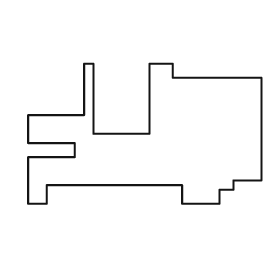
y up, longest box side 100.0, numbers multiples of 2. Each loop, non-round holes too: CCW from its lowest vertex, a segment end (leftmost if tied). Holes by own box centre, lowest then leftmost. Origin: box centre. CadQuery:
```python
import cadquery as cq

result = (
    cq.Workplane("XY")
    .moveTo(-50.0, -30.0)
    .lineTo(-42.0, -30.0)
    .lineTo(-42.0, -22.0)
    .lineTo(16.0, -22.0)
    .lineTo(16.0, -30.0)
    .lineTo(32.0, -30.0)
    .lineTo(32.0, -24.0)
    .lineTo(38.0, -24.0)
    .lineTo(38.0, -20.0)
    .lineTo(50.0, -20.0)
    .lineTo(50.0, 24.0)
    .lineTo(12.0, 24.0)
    .lineTo(12.0, 30.0)
    .lineTo(2.0, 30.0)
    .lineTo(2.0, 0.0)
    .lineTo(-22.0, 0.0)
    .lineTo(-22.0, 30.0)
    .lineTo(-26.0, 30.0)
    .lineTo(-26.0, 8.0)
    .lineTo(-50.0, 8.0)
    .lineTo(-50.0, -4.0)
    .lineTo(-30.0, -4.0)
    .lineTo(-30.0, -10.0)
    .lineTo(-50.0, -10.0)
    .close()
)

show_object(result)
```